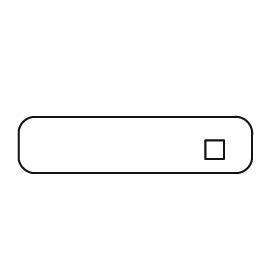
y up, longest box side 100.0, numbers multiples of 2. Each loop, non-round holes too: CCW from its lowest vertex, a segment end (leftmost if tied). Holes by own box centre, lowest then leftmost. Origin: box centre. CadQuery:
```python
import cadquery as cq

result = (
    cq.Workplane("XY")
    .moveTo(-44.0, -12.0)
    .lineTo(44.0, -12.0)
    .threePointArc((48.0, -10.0), (50.0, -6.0))
    .lineTo(50.0, 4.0)
    .threePointArc((48.0, 10.0), (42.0, 12.0))
    .lineTo(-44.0, 12.0)
    .threePointArc((-48.0, 10.0), (-50.0, 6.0))
    .lineTo(-50.0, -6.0)
    .threePointArc((-48.0, -10.0), (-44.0, -12.0))
    .close()
    .moveTo(30.0, -6.0)
    .lineTo(38.0, -6.0)
    .lineTo(38.0, 2.0)
    .lineTo(30.0, 2.0)
    .close()
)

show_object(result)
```